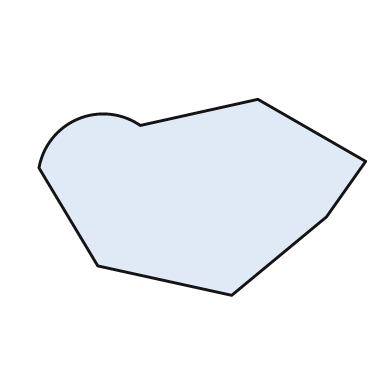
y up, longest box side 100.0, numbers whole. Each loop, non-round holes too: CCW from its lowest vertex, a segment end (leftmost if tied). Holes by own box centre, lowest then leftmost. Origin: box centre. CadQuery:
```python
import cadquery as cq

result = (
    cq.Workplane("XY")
    .moveTo(9.0, -30.0)
    .lineTo(38.0, -6.0)
    .lineTo(50.0, 11.0)
    .lineTo(17.0, 30.0)
    .lineTo(-19.0, 22.0)
    .threePointArc((-38.0, 24.0), (-50.0, 9.0))
    .lineTo(-32.0, -21.0)
    .close()
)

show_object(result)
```